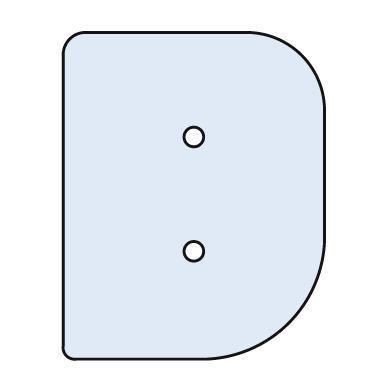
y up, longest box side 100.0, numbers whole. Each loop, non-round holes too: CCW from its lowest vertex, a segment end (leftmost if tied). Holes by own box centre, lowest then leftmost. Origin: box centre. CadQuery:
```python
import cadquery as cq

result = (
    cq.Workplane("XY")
    .moveTo(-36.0, -50.0)
    .lineTo(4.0, -50.0)
    .threePointArc((29.0, -39.0), (40.0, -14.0))
    .lineTo(40.0, 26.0)
    .threePointArc((33.0, 43.0), (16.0, 50.0))
    .lineTo(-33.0, 50.0)
    .threePointArc((-38.0, 48.0), (-40.0, 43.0))
    .lineTo(-40.0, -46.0)
    .threePointArc((-39.0, -49.0), (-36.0, -50.0))
    .close()
    .moveTo(0.0, -17.0)
    .circle(3.0)
    .moveTo(0.0, 18.0)
    .circle(3.0)
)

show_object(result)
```